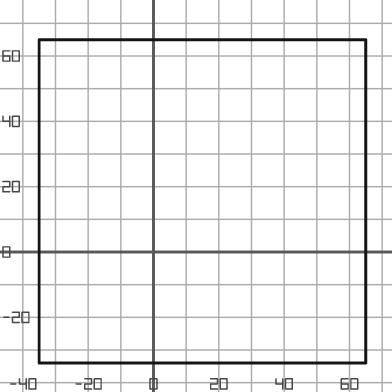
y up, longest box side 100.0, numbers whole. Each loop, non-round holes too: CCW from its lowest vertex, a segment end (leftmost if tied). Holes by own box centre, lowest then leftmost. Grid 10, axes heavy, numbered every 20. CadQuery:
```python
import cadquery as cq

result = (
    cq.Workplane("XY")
    .moveTo(-35.0, -34.0)
    .lineTo(65.0, -34.0)
    .lineTo(65.0, 65.0)
    .lineTo(-35.0, 65.0)
    .close()
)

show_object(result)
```